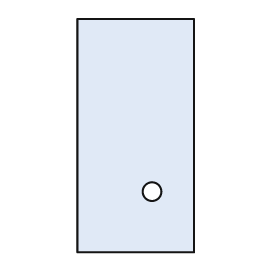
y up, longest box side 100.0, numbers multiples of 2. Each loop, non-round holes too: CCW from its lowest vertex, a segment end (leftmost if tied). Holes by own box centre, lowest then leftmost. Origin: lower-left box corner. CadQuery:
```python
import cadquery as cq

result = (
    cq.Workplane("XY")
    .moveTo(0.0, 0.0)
    .lineTo(50.0, 0.0)
    .lineTo(50.0, 100.0)
    .lineTo(0.0, 100.0)
    .close()
    .moveTo(32.0, 26.0)
    .circle(4.0)
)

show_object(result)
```